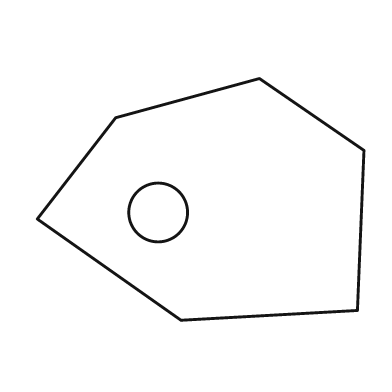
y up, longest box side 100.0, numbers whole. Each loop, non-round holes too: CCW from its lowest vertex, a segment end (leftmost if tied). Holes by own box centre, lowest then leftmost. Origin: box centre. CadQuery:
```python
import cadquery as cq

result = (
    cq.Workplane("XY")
    .moveTo(-6.0, -37.0)
    .lineTo(48.0, -34.0)
    .lineTo(50.0, 15.0)
    .lineTo(18.0, 37.0)
    .lineTo(-26.0, 25.0)
    .lineTo(-50.0, -6.0)
    .close()
    .moveTo(-13.0, -4.0)
    .circle(9.0)
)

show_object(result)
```